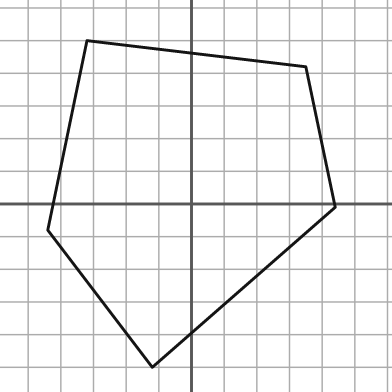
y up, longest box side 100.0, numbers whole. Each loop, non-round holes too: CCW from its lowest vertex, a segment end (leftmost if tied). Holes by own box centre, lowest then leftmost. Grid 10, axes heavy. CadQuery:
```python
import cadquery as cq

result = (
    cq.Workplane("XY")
    .moveTo(-12.0, -50.0)
    .lineTo(44.0, -1.0)
    .lineTo(35.0, 42.0)
    .lineTo(-32.0, 50.0)
    .lineTo(-44.0, -8.0)
    .close()
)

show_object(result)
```